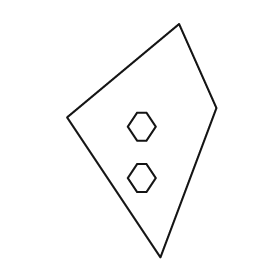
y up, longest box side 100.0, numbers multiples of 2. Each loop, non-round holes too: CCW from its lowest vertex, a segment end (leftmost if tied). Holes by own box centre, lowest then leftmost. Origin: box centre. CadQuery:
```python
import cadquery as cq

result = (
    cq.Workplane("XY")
    .moveTo(8.0, -50.0)
    .lineTo(32.0, 14.0)
    .lineTo(16.0, 50.0)
    .lineTo(-32.0, 10.0)
    .close()
    .moveTo(-2.0, -22.0)
    .lineTo(2.0, -22.0)
    .lineTo(6.0, -16.0)
    .lineTo(2.0, -10.0)
    .lineTo(-2.0, -10.0)
    .lineTo(-6.0, -16.0)
    .close()
    .moveTo(-2.0, 0.0)
    .lineTo(2.0, 0.0)
    .lineTo(6.0, 6.0)
    .lineTo(2.0, 12.0)
    .lineTo(-2.0, 12.0)
    .lineTo(-6.0, 6.0)
    .close()
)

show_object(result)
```